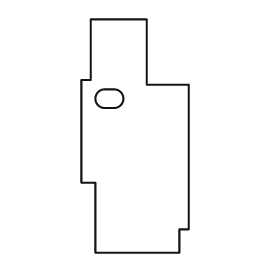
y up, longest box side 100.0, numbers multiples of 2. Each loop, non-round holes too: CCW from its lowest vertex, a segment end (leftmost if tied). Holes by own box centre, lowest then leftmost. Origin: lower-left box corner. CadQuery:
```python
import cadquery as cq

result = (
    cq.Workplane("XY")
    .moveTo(6.0, 0.0)
    .lineTo(42.0, 0.0)
    .lineTo(42.0, 10.0)
    .lineTo(46.0, 10.0)
    .lineTo(46.0, 72.0)
    .lineTo(28.0, 72.0)
    .lineTo(28.0, 100.0)
    .lineTo(4.0, 100.0)
    .lineTo(4.0, 74.0)
    .lineTo(0.0, 74.0)
    .lineTo(0.0, 30.0)
    .lineTo(6.0, 30.0)
    .close()
    .moveTo(10.0, 62.0)
    .lineTo(14.0, 62.0)
    .threePointArc((18.0, 66.0), (14.0, 70.0))
    .lineTo(10.0, 70.0)
    .threePointArc((6.0, 66.0), (10.0, 62.0))
    .close()
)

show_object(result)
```